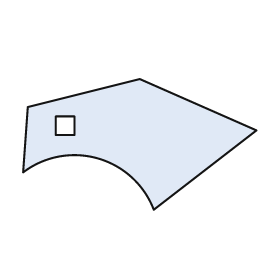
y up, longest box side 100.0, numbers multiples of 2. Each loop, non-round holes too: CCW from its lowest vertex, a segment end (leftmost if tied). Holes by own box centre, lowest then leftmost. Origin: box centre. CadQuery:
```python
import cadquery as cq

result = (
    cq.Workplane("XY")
    .moveTo(6.0, -28.0)
    .lineTo(50.0, 6.0)
    .lineTo(0.0, 28.0)
    .lineTo(-48.0, 16.0)
    .lineTo(-50.0, -12.0)
    .threePointArc((-18.0, -6.0), (6.0, -28.0))
    .close()
    .moveTo(-36.0, 4.0)
    .lineTo(-28.0, 4.0)
    .lineTo(-28.0, 12.0)
    .lineTo(-36.0, 12.0)
    .close()
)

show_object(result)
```